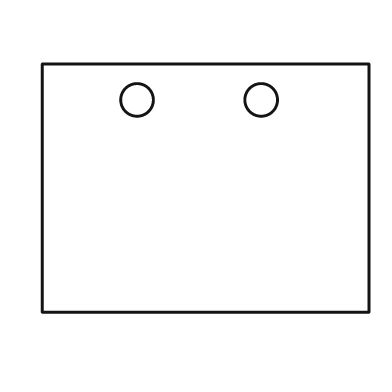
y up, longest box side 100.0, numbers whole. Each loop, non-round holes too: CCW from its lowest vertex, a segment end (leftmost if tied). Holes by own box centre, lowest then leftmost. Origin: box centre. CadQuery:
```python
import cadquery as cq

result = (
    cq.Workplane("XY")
    .moveTo(-50.0, -38.0)
    .lineTo(50.0, -38.0)
    .lineTo(50.0, 38.0)
    .lineTo(-50.0, 38.0)
    .close()
    .moveTo(-21.0, 27.0)
    .circle(5.0)
    .moveTo(17.0, 27.0)
    .circle(5.0)
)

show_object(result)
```